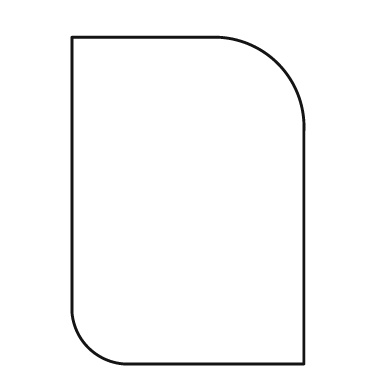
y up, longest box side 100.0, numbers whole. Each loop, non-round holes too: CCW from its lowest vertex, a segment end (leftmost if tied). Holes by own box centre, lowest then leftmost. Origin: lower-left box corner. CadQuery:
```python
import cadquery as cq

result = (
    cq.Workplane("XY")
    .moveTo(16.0, 0.0)
    .lineTo(71.0, 0.0)
    .lineTo(71.0, 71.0)
    .threePointArc((63.0, 92.0), (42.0, 100.0))
    .lineTo(0.0, 100.0)
    .lineTo(0.0, 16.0)
    .threePointArc((5.0, 5.0), (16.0, 0.0))
    .close()
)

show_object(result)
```